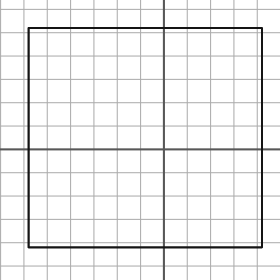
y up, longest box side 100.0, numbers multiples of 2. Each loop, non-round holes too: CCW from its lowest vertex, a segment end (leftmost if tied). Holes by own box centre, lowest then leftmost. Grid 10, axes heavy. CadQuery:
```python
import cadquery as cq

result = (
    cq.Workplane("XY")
    .moveTo(-58.0, -42.0)
    .lineTo(42.0, -42.0)
    .lineTo(42.0, 52.0)
    .lineTo(-58.0, 52.0)
    .close()
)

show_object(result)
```